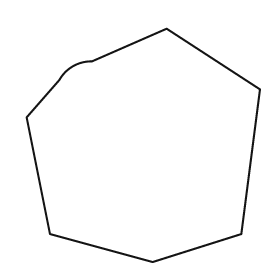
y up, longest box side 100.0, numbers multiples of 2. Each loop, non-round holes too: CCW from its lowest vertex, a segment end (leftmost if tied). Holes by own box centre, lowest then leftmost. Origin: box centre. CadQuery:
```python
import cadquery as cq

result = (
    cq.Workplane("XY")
    .moveTo(4.0, -50.0)
    .lineTo(42.0, -38.0)
    .lineTo(50.0, 24.0)
    .lineTo(10.0, 50.0)
    .lineTo(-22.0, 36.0)
    .threePointArc((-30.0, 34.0), (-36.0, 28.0))
    .lineTo(-50.0, 12.0)
    .lineTo(-40.0, -38.0)
    .close()
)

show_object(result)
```